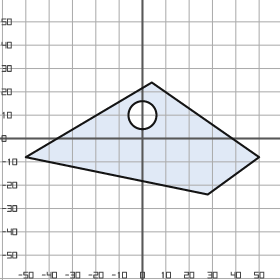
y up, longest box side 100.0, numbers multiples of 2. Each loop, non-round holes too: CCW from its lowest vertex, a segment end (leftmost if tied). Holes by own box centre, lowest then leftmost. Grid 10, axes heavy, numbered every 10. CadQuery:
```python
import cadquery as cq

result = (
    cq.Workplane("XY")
    .moveTo(28.0, -24.0)
    .lineTo(50.0, -8.0)
    .lineTo(4.0, 24.0)
    .lineTo(-50.0, -8.0)
    .close()
    .moveTo(0.0, 10.0)
    .circle(6.0)
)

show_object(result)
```